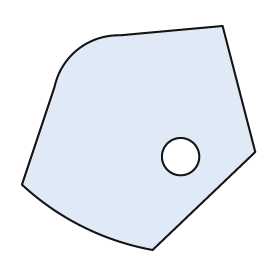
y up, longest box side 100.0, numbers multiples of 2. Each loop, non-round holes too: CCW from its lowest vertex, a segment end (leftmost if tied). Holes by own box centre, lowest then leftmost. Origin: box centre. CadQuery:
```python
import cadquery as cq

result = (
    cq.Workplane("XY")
    .moveTo(6.0, -48.0)
    .lineTo(50.0, -6.0)
    .lineTo(36.0, 48.0)
    .lineTo(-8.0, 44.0)
    .threePointArc((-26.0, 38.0), (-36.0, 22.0))
    .lineTo(-50.0, -20.0)
    .threePointArc((-24.0, -38.0), (6.0, -48.0))
    .close()
    .moveTo(18.0, -8.0)
    .circle(8.0)
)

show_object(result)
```